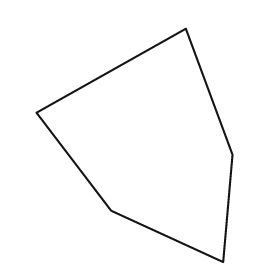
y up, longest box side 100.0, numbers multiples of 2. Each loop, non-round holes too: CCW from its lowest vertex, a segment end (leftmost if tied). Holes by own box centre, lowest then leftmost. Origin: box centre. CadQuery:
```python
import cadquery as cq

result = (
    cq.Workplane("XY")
    .moveTo(38.0, -50.0)
    .lineTo(42.0, -4.0)
    .lineTo(22.0, 50.0)
    .lineTo(-42.0, 14.0)
    .lineTo(-10.0, -28.0)
    .close()
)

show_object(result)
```